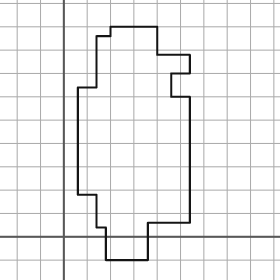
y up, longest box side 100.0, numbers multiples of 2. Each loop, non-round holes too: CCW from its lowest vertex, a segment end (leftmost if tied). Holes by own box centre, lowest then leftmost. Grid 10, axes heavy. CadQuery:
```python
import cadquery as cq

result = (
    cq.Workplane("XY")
    .moveTo(18.0, -10.0)
    .lineTo(36.0, -10.0)
    .lineTo(36.0, 6.0)
    .lineTo(54.0, 6.0)
    .lineTo(54.0, 60.0)
    .lineTo(46.0, 60.0)
    .lineTo(46.0, 70.0)
    .lineTo(54.0, 70.0)
    .lineTo(54.0, 78.0)
    .lineTo(40.0, 78.0)
    .lineTo(40.0, 90.0)
    .lineTo(20.0, 90.0)
    .lineTo(20.0, 86.0)
    .lineTo(14.0, 86.0)
    .lineTo(14.0, 64.0)
    .lineTo(6.0, 64.0)
    .lineTo(6.0, 18.0)
    .lineTo(14.0, 18.0)
    .lineTo(14.0, 4.0)
    .lineTo(18.0, 4.0)
    .close()
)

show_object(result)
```